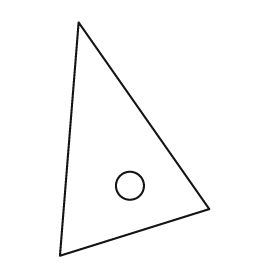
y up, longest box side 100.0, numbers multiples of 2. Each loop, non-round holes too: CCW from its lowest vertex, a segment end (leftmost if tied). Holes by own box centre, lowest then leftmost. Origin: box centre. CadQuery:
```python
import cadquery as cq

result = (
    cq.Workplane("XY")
    .moveTo(-32.0, -50.0)
    .lineTo(32.0, -30.0)
    .lineTo(-24.0, 50.0)
    .close()
    .moveTo(-2.0, -20.0)
    .circle(6.0)
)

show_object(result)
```